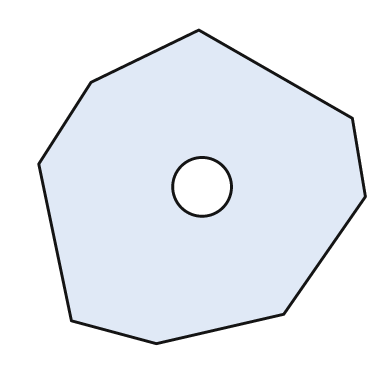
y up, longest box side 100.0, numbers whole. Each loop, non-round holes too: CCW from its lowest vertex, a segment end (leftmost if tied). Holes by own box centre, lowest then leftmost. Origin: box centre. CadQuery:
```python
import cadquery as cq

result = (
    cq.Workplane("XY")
    .moveTo(-14.0, -48.0)
    .lineTo(25.0, -39.0)
    .lineTo(50.0, -3.0)
    .lineTo(46.0, 21.0)
    .lineTo(-1.0, 48.0)
    .lineTo(-34.0, 32.0)
    .lineTo(-50.0, 7.0)
    .lineTo(-40.0, -41.0)
    .close()
    .moveTo(0.0, 0.0)
    .circle(9.0)
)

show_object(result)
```